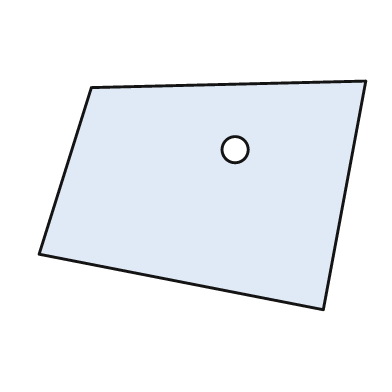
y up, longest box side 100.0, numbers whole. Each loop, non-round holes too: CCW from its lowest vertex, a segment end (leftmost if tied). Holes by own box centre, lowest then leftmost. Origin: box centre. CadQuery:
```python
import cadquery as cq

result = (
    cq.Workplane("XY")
    .moveTo(37.0, -35.0)
    .lineTo(50.0, 35.0)
    .lineTo(-34.0, 33.0)
    .lineTo(-50.0, -18.0)
    .close()
    .moveTo(10.0, 14.0)
    .circle(4.0)
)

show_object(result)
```